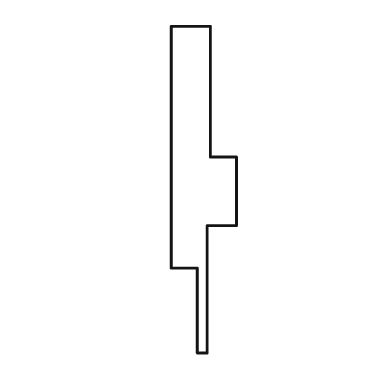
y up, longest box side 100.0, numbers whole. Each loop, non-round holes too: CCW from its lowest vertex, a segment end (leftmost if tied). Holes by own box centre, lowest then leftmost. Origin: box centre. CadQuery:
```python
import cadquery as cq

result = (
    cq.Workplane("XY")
    .moveTo(-2.0, -50.0)
    .lineTo(1.0, -50.0)
    .lineTo(1.0, -11.0)
    .lineTo(10.0, -11.0)
    .lineTo(10.0, 10.0)
    .lineTo(2.0, 10.0)
    .lineTo(2.0, 50.0)
    .lineTo(-10.0, 50.0)
    .lineTo(-10.0, -24.0)
    .lineTo(-2.0, -24.0)
    .close()
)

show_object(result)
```